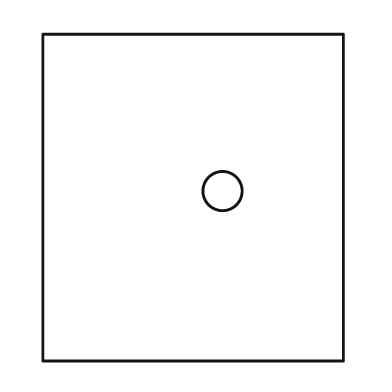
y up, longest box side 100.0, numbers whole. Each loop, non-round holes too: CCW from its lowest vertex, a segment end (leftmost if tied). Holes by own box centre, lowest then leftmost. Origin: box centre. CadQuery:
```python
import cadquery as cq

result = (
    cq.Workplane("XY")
    .moveTo(-46.0, -50.0)
    .lineTo(46.0, -50.0)
    .lineTo(46.0, 50.0)
    .lineTo(-46.0, 50.0)
    .close()
    .moveTo(9.0, 2.0)
    .circle(6.0)
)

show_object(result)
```